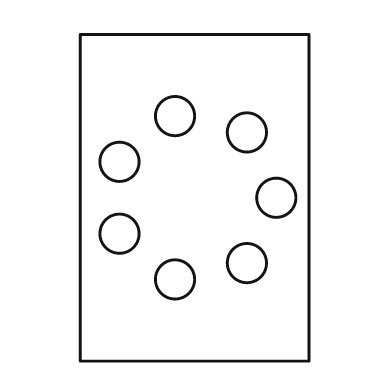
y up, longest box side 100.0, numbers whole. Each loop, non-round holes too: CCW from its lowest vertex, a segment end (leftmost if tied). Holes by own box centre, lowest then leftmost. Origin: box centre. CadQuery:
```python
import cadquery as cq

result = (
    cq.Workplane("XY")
    .moveTo(-35.0, -50.0)
    .lineTo(35.0, -50.0)
    .lineTo(35.0, 50.0)
    .lineTo(-35.0, 50.0)
    .close()
    .moveTo(-6.0, -25.0)
    .circle(6.0)
    .moveTo(16.0, -20.0)
    .circle(6.0)
    .moveTo(-23.0, -11.0)
    .circle(6.0)
    .moveTo(25.0, 0.0)
    .circle(6.0)
    .moveTo(-23.0, 11.0)
    .circle(6.0)
    .moveTo(16.0, 20.0)
    .circle(6.0)
    .moveTo(-6.0, 25.0)
    .circle(6.0)
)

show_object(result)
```